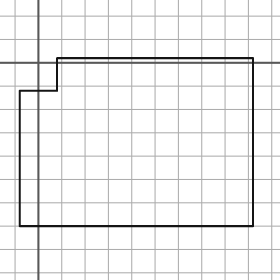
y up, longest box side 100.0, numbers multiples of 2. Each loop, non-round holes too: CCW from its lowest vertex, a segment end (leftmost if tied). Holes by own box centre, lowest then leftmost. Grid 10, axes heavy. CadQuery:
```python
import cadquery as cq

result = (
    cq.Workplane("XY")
    .moveTo(-8.0, -70.0)
    .lineTo(92.0, -70.0)
    .lineTo(92.0, 2.0)
    .lineTo(8.0, 2.0)
    .lineTo(8.0, -12.0)
    .lineTo(-8.0, -12.0)
    .close()
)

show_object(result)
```